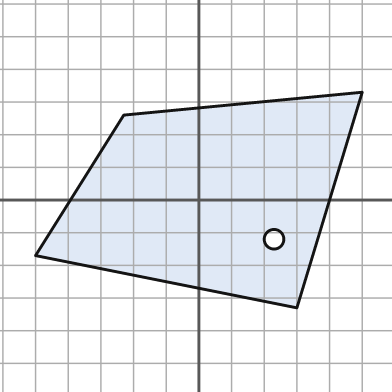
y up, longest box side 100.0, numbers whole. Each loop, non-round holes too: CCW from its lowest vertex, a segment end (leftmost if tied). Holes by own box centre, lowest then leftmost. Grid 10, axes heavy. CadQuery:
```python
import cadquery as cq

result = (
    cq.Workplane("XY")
    .moveTo(30.0, -33.0)
    .lineTo(50.0, 33.0)
    .lineTo(-23.0, 26.0)
    .lineTo(-50.0, -17.0)
    .close()
    .moveTo(23.0, -12.0)
    .circle(3.0)
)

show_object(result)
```